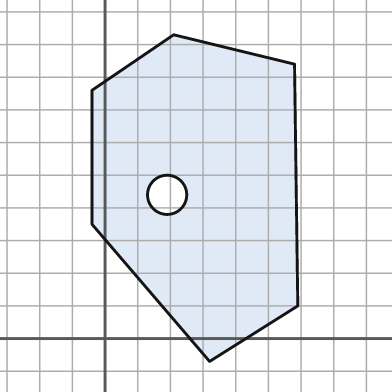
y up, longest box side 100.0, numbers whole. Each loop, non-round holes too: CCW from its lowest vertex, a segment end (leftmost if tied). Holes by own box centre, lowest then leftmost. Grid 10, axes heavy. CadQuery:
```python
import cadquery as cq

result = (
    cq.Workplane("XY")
    .moveTo(32.0, -7.0)
    .lineTo(59.0, 10.0)
    .lineTo(58.0, 84.0)
    .lineTo(21.0, 93.0)
    .lineTo(-4.0, 76.0)
    .lineTo(-4.0, 35.0)
    .close()
    .moveTo(19.0, 44.0)
    .circle(6.0)
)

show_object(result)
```